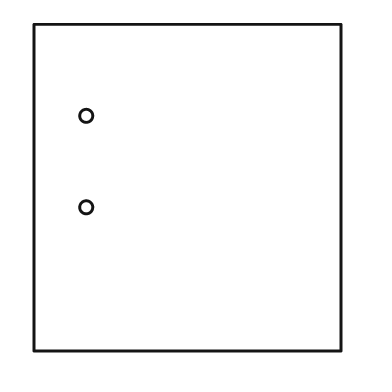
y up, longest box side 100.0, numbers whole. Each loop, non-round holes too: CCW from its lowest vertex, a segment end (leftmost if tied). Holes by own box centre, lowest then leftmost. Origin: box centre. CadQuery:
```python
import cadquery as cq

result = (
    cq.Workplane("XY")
    .moveTo(-47.0, -50.0)
    .lineTo(47.0, -50.0)
    .lineTo(47.0, 50.0)
    .lineTo(-47.0, 50.0)
    .close()
    .moveTo(-31.0, -6.0)
    .circle(2.0)
    .moveTo(-31.0, 22.0)
    .circle(2.0)
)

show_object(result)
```